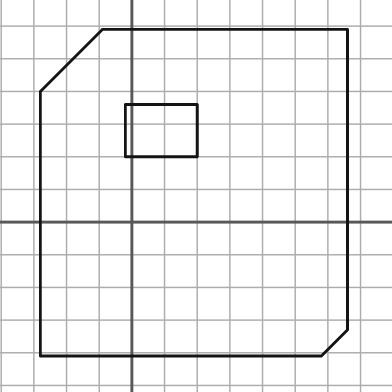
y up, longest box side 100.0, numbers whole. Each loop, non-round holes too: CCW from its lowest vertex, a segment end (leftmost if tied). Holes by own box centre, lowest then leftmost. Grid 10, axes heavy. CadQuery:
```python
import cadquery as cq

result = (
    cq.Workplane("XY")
    .moveTo(-28.0, -41.0)
    .lineTo(58.0, -41.0)
    .lineTo(66.0, -33.0)
    .lineTo(66.0, 59.0)
    .lineTo(-9.0, 59.0)
    .lineTo(-28.0, 40.0)
    .close()
    .moveTo(-2.0, 20.0)
    .lineTo(20.0, 20.0)
    .lineTo(20.0, 36.0)
    .lineTo(-2.0, 36.0)
    .close()
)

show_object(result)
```